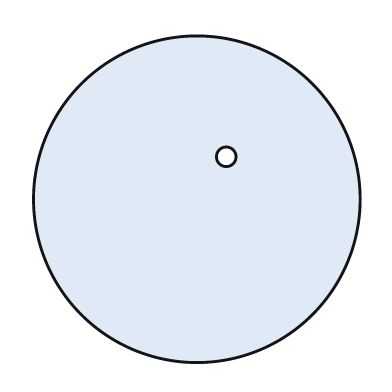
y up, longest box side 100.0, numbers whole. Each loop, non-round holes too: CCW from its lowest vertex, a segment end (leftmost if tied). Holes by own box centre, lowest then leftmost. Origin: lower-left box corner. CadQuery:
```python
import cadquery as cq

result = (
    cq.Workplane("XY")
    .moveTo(50.0, 50.0)
    .circle(50.0)
    .moveTo(59.0, 63.0)
    .circle(3.0)
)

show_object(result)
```